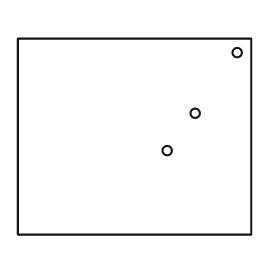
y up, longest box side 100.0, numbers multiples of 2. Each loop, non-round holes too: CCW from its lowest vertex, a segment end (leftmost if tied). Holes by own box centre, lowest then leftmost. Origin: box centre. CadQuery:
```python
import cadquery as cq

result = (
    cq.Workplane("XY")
    .moveTo(-50.0, -42.0)
    .lineTo(50.0, -42.0)
    .lineTo(50.0, 42.0)
    .lineTo(-50.0, 42.0)
    .close()
    .moveTo(14.0, -6.0)
    .circle(2.0)
    .moveTo(26.0, 10.0)
    .circle(2.0)
    .moveTo(44.0, 36.0)
    .circle(2.0)
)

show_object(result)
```